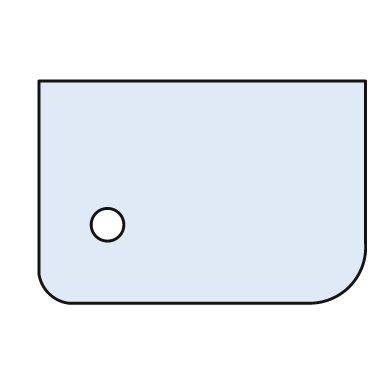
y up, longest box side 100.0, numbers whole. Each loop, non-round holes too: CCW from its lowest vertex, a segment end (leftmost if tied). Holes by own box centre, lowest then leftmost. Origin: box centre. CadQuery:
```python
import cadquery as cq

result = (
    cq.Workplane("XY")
    .moveTo(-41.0, -34.0)
    .lineTo(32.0, -34.0)
    .threePointArc((45.0, -29.0), (50.0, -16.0))
    .lineTo(50.0, 34.0)
    .lineTo(-50.0, 34.0)
    .lineTo(-50.0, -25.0)
    .threePointArc((-47.0, -31.0), (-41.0, -34.0))
    .close()
    .moveTo(-29.0, -10.0)
    .circle(5.0)
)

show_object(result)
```